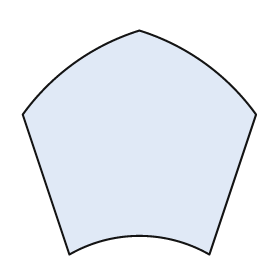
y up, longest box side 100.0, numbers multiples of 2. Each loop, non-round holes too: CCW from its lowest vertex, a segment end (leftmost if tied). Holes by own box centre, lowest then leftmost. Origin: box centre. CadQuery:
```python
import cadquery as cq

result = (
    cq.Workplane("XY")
    .moveTo(-30.0, -48.0)
    .threePointArc((0.0, -40.0), (30.0, -48.0))
    .lineTo(50.0, 12.0)
    .threePointArc((28.0, 34.0), (0.0, 48.0))
    .threePointArc((-28.0, 34.0), (-50.0, 12.0))
    .close()
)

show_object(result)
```